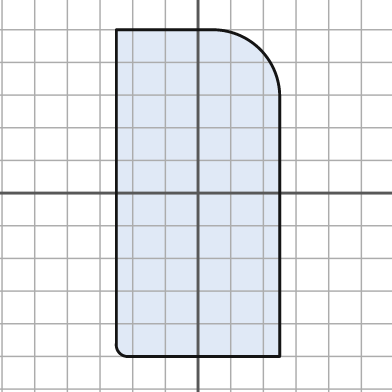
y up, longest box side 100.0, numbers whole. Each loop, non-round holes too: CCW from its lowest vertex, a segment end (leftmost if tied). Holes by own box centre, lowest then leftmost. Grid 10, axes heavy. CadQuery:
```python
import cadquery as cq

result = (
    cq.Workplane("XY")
    .moveTo(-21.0, -50.0)
    .lineTo(25.0, -50.0)
    .lineTo(25.0, 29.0)
    .threePointArc((19.0, 44.0), (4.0, 50.0))
    .lineTo(-25.0, 50.0)
    .lineTo(-25.0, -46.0)
    .threePointArc((-24.0, -49.0), (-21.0, -50.0))
    .close()
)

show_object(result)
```